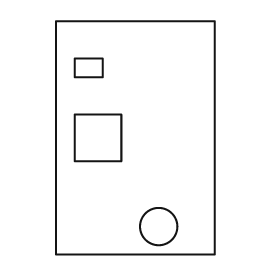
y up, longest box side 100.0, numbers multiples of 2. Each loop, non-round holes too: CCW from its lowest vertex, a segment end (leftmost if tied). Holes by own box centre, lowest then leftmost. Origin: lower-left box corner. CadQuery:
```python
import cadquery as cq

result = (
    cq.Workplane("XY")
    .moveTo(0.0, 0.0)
    .lineTo(68.0, 0.0)
    .lineTo(68.0, 100.0)
    .lineTo(0.0, 100.0)
    .close()
    .moveTo(44.0, 12.0)
    .circle(8.0)
    .moveTo(8.0, 40.0)
    .lineTo(28.0, 40.0)
    .lineTo(28.0, 60.0)
    .lineTo(8.0, 60.0)
    .close()
    .moveTo(8.0, 76.0)
    .lineTo(20.0, 76.0)
    .lineTo(20.0, 84.0)
    .lineTo(8.0, 84.0)
    .close()
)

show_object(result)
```